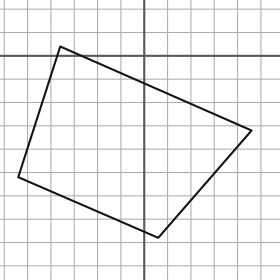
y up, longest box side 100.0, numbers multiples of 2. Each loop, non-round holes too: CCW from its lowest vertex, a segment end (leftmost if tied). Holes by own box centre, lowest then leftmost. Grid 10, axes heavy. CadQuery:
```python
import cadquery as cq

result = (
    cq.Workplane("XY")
    .moveTo(6.0, -78.0)
    .lineTo(46.0, -32.0)
    .lineTo(-36.0, 4.0)
    .lineTo(-54.0, -52.0)
    .close()
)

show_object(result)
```